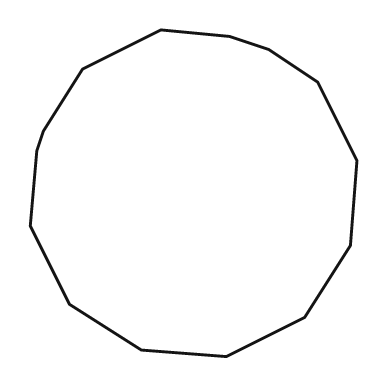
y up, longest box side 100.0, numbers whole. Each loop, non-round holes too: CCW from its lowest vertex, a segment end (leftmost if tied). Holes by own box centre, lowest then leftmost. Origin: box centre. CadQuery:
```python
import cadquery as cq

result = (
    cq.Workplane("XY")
    .moveTo(10.0, -50.0)
    .lineTo(34.0, -38.0)
    .lineTo(48.0, -16.0)
    .lineTo(50.0, 10.0)
    .lineTo(38.0, 34.0)
    .lineTo(23.0, 44.0)
    .lineTo(11.0, 48.0)
    .lineTo(-10.0, 50.0)
    .lineTo(-34.0, 38.0)
    .lineTo(-46.0, 19.0)
    .lineTo(-48.0, 13.0)
    .lineTo(-50.0, -10.0)
    .lineTo(-38.0, -34.0)
    .lineTo(-16.0, -48.0)
    .close()
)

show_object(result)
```